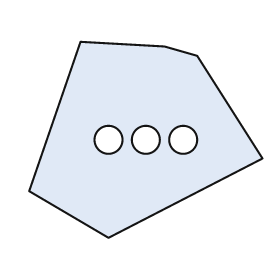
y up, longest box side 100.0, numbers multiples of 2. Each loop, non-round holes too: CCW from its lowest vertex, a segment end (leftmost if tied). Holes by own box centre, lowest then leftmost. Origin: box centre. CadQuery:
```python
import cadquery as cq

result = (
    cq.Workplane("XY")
    .moveTo(-16.0, -42.0)
    .lineTo(50.0, -8.0)
    .lineTo(22.0, 36.0)
    .lineTo(8.0, 40.0)
    .lineTo(-28.0, 42.0)
    .lineTo(-50.0, -22.0)
    .close()
    .moveTo(-16.0, 0.0)
    .circle(6.0)
    .moveTo(0.0, 0.0)
    .circle(6.0)
    .moveTo(16.0, 0.0)
    .circle(6.0)
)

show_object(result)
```